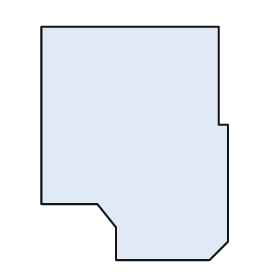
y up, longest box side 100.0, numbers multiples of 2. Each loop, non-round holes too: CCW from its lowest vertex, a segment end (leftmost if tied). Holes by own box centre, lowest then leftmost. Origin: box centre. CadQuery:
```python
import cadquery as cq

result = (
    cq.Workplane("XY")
    .moveTo(-8.0, -50.0)
    .lineTo(32.0, -50.0)
    .lineTo(40.0, -42.0)
    .lineTo(40.0, 8.0)
    .lineTo(36.0, 8.0)
    .lineTo(36.0, 50.0)
    .lineTo(-40.0, 50.0)
    .lineTo(-40.0, -26.0)
    .lineTo(-16.0, -26.0)
    .lineTo(-8.0, -36.0)
    .close()
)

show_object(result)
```